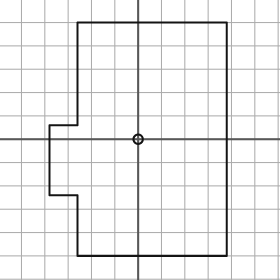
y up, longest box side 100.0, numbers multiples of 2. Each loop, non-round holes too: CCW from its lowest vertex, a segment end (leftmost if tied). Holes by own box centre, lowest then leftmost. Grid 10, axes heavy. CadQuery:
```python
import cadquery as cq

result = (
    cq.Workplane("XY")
    .moveTo(-26.0, -50.0)
    .lineTo(38.0, -50.0)
    .lineTo(38.0, 50.0)
    .lineTo(-26.0, 50.0)
    .lineTo(-26.0, 6.0)
    .lineTo(-38.0, 6.0)
    .lineTo(-38.0, -24.0)
    .lineTo(-26.0, -24.0)
    .close()
    .moveTo(0.0, 0.0)
    .circle(2.0)
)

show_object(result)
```